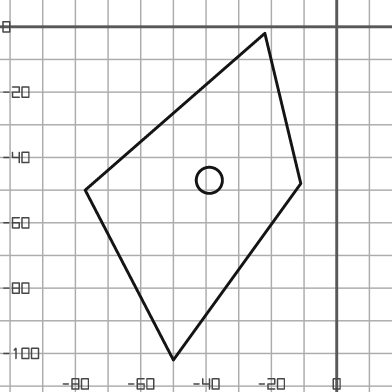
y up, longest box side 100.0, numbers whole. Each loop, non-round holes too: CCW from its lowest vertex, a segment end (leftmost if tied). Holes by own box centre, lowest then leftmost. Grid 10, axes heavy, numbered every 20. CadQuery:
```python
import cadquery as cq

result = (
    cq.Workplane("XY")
    .moveTo(-50.0, -102.0)
    .lineTo(-11.0, -48.0)
    .lineTo(-22.0, -2.0)
    .lineTo(-77.0, -50.0)
    .close()
    .moveTo(-39.0, -47.0)
    .circle(4.0)
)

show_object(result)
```